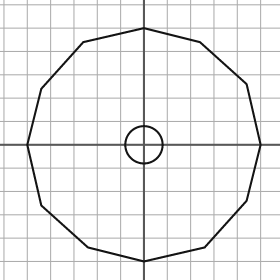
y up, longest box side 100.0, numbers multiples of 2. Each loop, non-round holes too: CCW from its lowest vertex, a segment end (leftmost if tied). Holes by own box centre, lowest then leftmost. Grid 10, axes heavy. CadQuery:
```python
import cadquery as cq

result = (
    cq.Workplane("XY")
    .moveTo(0.0, -50.0)
    .lineTo(26.0, -44.0)
    .lineTo(44.0, -24.0)
    .lineTo(50.0, 0.0)
    .lineTo(44.0, 26.0)
    .lineTo(24.0, 44.0)
    .lineTo(0.0, 50.0)
    .lineTo(-26.0, 44.0)
    .lineTo(-44.0, 24.0)
    .lineTo(-50.0, 0.0)
    .lineTo(-44.0, -26.0)
    .lineTo(-24.0, -44.0)
    .close()
    .moveTo(0.0, 0.0)
    .circle(8.0)
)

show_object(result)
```